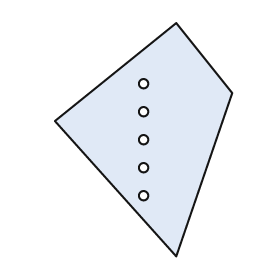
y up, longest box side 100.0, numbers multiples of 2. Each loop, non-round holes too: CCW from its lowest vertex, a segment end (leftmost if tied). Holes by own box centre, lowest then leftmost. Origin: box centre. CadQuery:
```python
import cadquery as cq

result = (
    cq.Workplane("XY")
    .moveTo(14.0, -50.0)
    .lineTo(38.0, 20.0)
    .lineTo(14.0, 50.0)
    .lineTo(-38.0, 8.0)
    .close()
    .moveTo(0.0, -24.0)
    .circle(2.0)
    .moveTo(0.0, -12.0)
    .circle(2.0)
    .moveTo(0.0, 0.0)
    .circle(2.0)
    .moveTo(0.0, 12.0)
    .circle(2.0)
    .moveTo(0.0, 24.0)
    .circle(2.0)
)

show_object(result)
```